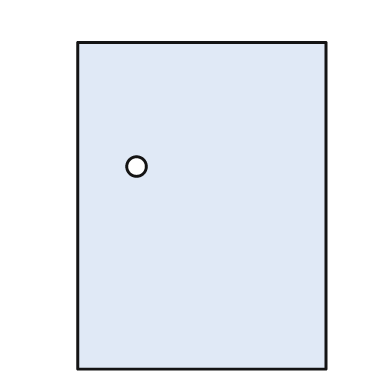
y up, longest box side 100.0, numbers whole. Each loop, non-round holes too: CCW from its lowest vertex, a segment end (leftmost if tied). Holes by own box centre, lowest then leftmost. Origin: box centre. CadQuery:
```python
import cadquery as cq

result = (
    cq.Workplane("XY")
    .moveTo(-38.0, -50.0)
    .lineTo(38.0, -50.0)
    .lineTo(38.0, 50.0)
    .lineTo(-38.0, 50.0)
    .close()
    .moveTo(-20.0, 12.0)
    .circle(3.0)
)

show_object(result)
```